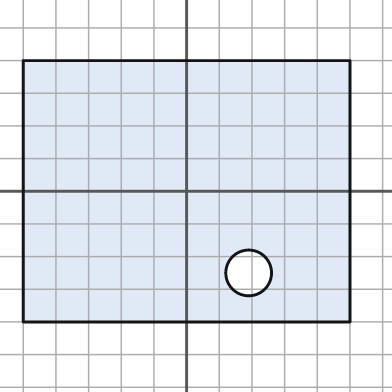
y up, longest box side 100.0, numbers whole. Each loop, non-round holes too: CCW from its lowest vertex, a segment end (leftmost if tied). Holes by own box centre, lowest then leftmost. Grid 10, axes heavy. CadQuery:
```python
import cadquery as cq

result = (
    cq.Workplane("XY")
    .moveTo(-50.0, -40.0)
    .lineTo(50.0, -40.0)
    .lineTo(50.0, 40.0)
    .lineTo(-50.0, 40.0)
    .close()
    .moveTo(19.0, -25.0)
    .circle(7.0)
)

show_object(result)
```